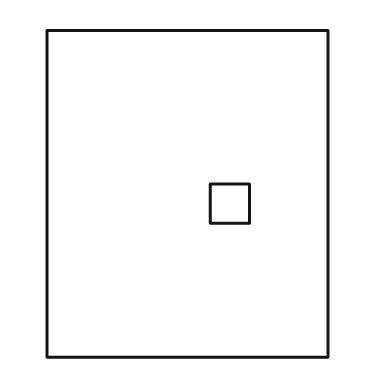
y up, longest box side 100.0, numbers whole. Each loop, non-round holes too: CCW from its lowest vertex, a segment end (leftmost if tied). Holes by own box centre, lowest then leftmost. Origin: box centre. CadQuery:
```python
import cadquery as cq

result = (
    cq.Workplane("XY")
    .moveTo(-43.0, -50.0)
    .lineTo(43.0, -50.0)
    .lineTo(43.0, 50.0)
    .lineTo(-43.0, 50.0)
    .close()
    .moveTo(7.0, -9.0)
    .lineTo(19.0, -9.0)
    .lineTo(19.0, 3.0)
    .lineTo(7.0, 3.0)
    .close()
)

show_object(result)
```